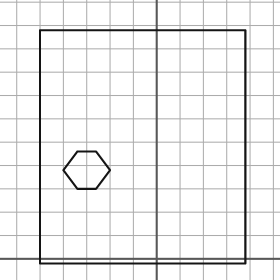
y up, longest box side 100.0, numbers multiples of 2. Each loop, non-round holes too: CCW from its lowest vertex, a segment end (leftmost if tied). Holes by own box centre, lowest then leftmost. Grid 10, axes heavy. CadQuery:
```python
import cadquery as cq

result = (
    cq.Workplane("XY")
    .moveTo(-50.0, -2.0)
    .lineTo(38.0, -2.0)
    .lineTo(38.0, 98.0)
    .lineTo(-50.0, 98.0)
    .close()
    .moveTo(-34.0, 30.0)
    .lineTo(-26.0, 30.0)
    .lineTo(-20.0, 38.0)
    .lineTo(-26.0, 46.0)
    .lineTo(-34.0, 46.0)
    .lineTo(-40.0, 38.0)
    .close()
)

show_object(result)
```